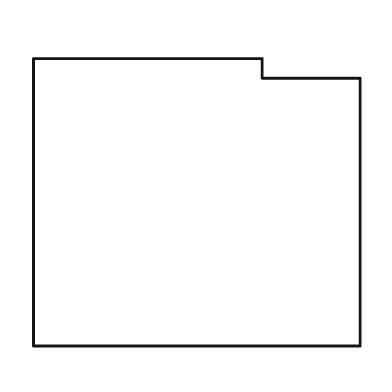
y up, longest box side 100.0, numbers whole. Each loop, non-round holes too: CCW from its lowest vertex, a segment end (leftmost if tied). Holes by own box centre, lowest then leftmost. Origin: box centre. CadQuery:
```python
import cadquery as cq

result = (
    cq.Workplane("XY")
    .moveTo(-50.0, -44.0)
    .lineTo(50.0, -44.0)
    .lineTo(50.0, 38.0)
    .lineTo(20.0, 38.0)
    .lineTo(20.0, 44.0)
    .lineTo(-50.0, 44.0)
    .close()
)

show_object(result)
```